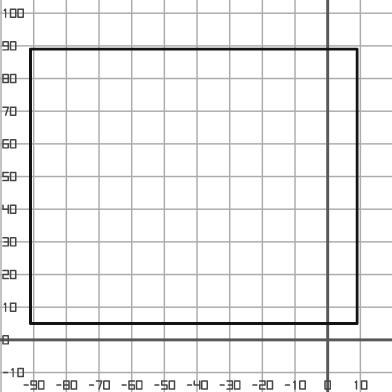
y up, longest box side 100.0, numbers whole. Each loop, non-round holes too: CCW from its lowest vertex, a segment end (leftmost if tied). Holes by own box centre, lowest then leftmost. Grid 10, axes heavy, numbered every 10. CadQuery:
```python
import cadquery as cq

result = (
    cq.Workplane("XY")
    .moveTo(-91.0, 5.0)
    .lineTo(9.0, 5.0)
    .lineTo(9.0, 89.0)
    .lineTo(-91.0, 89.0)
    .close()
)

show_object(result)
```